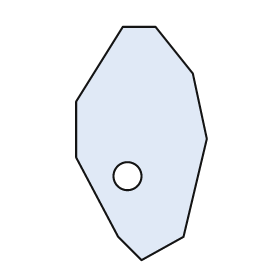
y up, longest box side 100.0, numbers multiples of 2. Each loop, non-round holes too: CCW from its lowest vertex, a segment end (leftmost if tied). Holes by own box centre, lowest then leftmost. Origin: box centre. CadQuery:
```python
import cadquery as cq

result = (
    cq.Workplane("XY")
    .moveTo(0.0, -50.0)
    .lineTo(18.0, -40.0)
    .lineTo(28.0, 2.0)
    .lineTo(22.0, 30.0)
    .lineTo(6.0, 50.0)
    .lineTo(-8.0, 50.0)
    .lineTo(-28.0, 18.0)
    .lineTo(-28.0, -6.0)
    .lineTo(-10.0, -40.0)
    .close()
    .moveTo(-6.0, -14.0)
    .circle(6.0)
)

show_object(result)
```